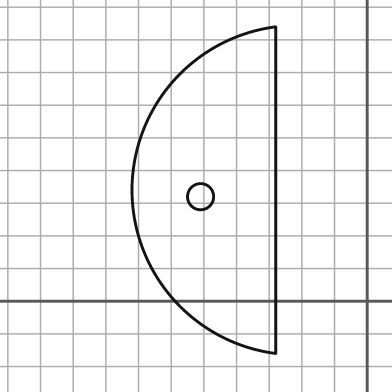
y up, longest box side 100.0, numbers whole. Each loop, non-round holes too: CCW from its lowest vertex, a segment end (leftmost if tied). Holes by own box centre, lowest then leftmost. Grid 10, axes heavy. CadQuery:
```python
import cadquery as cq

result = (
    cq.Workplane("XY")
    .moveTo(-28.0, -16.0)
    .lineTo(-28.0, 84.0)
    .threePointArc((-72.0, 34.0), (-28.0, -16.0))
    .close()
    .moveTo(-51.0, 32.0)
    .circle(4.0)
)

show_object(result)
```